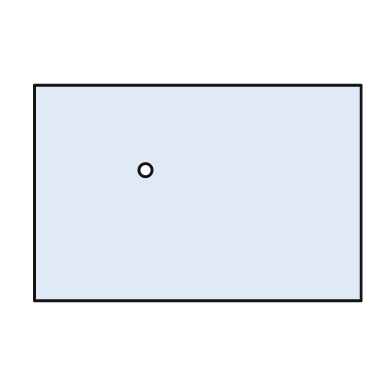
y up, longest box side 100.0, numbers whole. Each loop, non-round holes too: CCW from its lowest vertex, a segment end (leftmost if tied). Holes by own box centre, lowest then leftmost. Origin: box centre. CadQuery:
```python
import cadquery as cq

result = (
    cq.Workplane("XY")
    .moveTo(-50.0, -33.0)
    .lineTo(50.0, -33.0)
    .lineTo(50.0, 33.0)
    .lineTo(-50.0, 33.0)
    .close()
    .moveTo(-16.0, 7.0)
    .circle(2.0)
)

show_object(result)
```